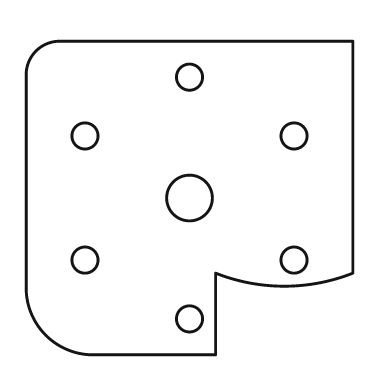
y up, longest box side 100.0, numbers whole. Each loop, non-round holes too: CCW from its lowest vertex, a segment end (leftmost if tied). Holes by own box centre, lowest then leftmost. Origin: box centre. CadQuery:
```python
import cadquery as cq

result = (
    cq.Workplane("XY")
    .moveTo(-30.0, -48.0)
    .lineTo(8.0, -48.0)
    .lineTo(8.0, -23.0)
    .threePointArc((29.0, -27.0), (50.0, -23.0))
    .lineTo(50.0, 48.0)
    .lineTo(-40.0, 48.0)
    .threePointArc((-47.0, 45.0), (-50.0, 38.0))
    .lineTo(-50.0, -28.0)
    .threePointArc((-44.0, -42.0), (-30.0, -48.0))
    .close()
    .moveTo(0.0, -37.0)
    .circle(4.0)
    .moveTo(-32.0, -19.0)
    .circle(4.0)
    .moveTo(32.0, -19.0)
    .circle(4.0)
    .moveTo(0.0, 0.0)
    .circle(7.0)
    .moveTo(-32.0, 19.0)
    .circle(4.0)
    .moveTo(32.0, 19.0)
    .circle(4.0)
    .moveTo(0.0, 37.0)
    .circle(4.0)
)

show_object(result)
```